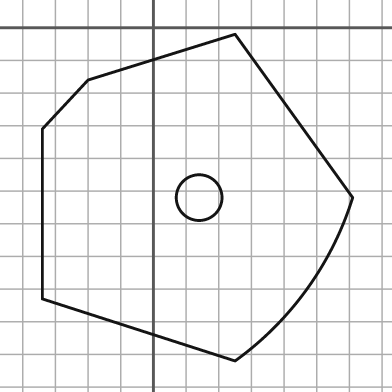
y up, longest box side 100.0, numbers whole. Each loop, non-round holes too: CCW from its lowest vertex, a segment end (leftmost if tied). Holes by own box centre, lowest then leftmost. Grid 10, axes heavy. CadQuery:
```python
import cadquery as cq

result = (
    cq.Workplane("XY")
    .moveTo(25.0, -102.0)
    .threePointArc((47.0, -80.0), (61.0, -52.0))
    .lineTo(25.0, -2.0)
    .lineTo(-20.0, -16.0)
    .lineTo(-34.0, -31.0)
    .lineTo(-34.0, -83.0)
    .close()
    .moveTo(14.0, -52.0)
    .circle(7.0)
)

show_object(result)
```